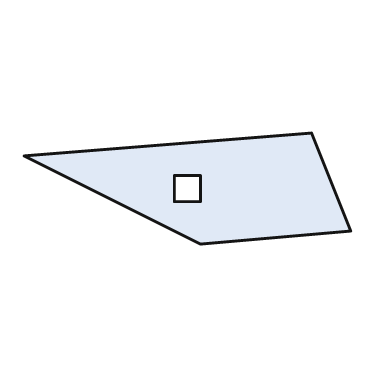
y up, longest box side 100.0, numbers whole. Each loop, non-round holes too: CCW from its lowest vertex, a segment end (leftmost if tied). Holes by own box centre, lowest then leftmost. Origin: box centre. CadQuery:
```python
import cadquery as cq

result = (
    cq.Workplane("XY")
    .moveTo(4.0, -17.0)
    .lineTo(50.0, -13.0)
    .lineTo(38.0, 17.0)
    .lineTo(-50.0, 10.0)
    .close()
    .moveTo(-4.0, -4.0)
    .lineTo(4.0, -4.0)
    .lineTo(4.0, 4.0)
    .lineTo(-4.0, 4.0)
    .close()
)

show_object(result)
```